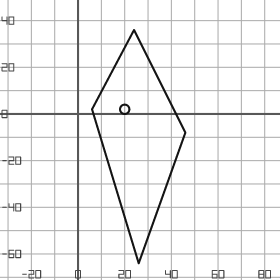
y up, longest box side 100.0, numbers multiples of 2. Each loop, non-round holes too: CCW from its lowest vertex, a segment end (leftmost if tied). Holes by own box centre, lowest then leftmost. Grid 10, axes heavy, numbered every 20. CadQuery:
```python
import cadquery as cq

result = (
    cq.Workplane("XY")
    .moveTo(26.0, -64.0)
    .lineTo(46.0, -8.0)
    .lineTo(24.0, 36.0)
    .lineTo(6.0, 2.0)
    .close()
    .moveTo(20.0, 2.0)
    .circle(2.0)
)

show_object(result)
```